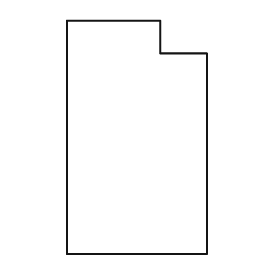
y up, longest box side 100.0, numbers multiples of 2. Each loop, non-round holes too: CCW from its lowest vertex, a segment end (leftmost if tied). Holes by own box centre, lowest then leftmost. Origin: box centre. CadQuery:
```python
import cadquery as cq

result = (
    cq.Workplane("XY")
    .moveTo(-30.0, -50.0)
    .lineTo(30.0, -50.0)
    .lineTo(30.0, 36.0)
    .lineTo(10.0, 36.0)
    .lineTo(10.0, 50.0)
    .lineTo(-30.0, 50.0)
    .close()
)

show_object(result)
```